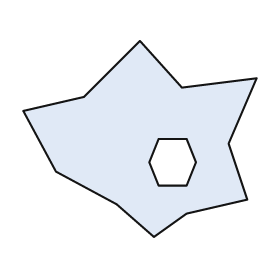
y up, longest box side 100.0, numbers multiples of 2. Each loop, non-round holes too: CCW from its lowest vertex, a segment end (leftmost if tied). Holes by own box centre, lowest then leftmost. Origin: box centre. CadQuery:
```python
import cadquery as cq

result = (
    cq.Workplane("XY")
    .moveTo(6.0, -42.0)
    .lineTo(20.0, -32.0)
    .lineTo(46.0, -26.0)
    .lineTo(38.0, -2.0)
    .lineTo(50.0, 26.0)
    .lineTo(18.0, 22.0)
    .lineTo(0.0, 42.0)
    .lineTo(-24.0, 18.0)
    .lineTo(-50.0, 12.0)
    .lineTo(-36.0, -14.0)
    .lineTo(-10.0, -28.0)
    .close()
    .moveTo(8.0, -20.0)
    .lineTo(20.0, -20.0)
    .lineTo(24.0, -10.0)
    .lineTo(20.0, 0.0)
    .lineTo(8.0, 0.0)
    .lineTo(4.0, -10.0)
    .close()
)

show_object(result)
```